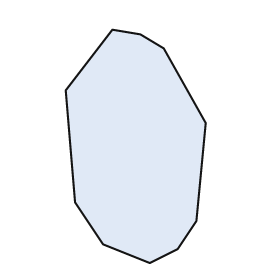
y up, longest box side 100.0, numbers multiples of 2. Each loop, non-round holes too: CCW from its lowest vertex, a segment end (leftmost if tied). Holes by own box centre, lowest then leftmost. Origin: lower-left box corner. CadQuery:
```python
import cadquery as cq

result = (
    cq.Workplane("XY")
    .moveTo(36.0, 0.0)
    .lineTo(48.0, 6.0)
    .lineTo(56.0, 18.0)
    .lineTo(60.0, 60.0)
    .lineTo(42.0, 92.0)
    .lineTo(32.0, 98.0)
    .lineTo(20.0, 100.0)
    .lineTo(0.0, 74.0)
    .lineTo(4.0, 26.0)
    .lineTo(16.0, 8.0)
    .close()
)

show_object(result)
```